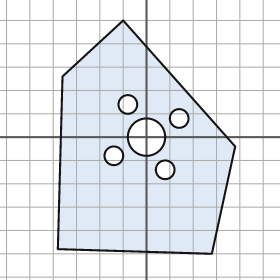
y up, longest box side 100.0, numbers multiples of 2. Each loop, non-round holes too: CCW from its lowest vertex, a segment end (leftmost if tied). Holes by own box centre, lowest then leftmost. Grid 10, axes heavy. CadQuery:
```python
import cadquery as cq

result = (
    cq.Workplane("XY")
    .moveTo(28.0, -50.0)
    .lineTo(38.0, -4.0)
    .lineTo(-10.0, 50.0)
    .lineTo(-36.0, 26.0)
    .lineTo(-38.0, -48.0)
    .close()
    .moveTo(8.0, -14.0)
    .circle(4.0)
    .moveTo(-14.0, -8.0)
    .circle(4.0)
    .moveTo(0.0, 0.0)
    .circle(8.0)
    .moveTo(14.0, 8.0)
    .circle(4.0)
    .moveTo(-8.0, 14.0)
    .circle(4.0)
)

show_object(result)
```